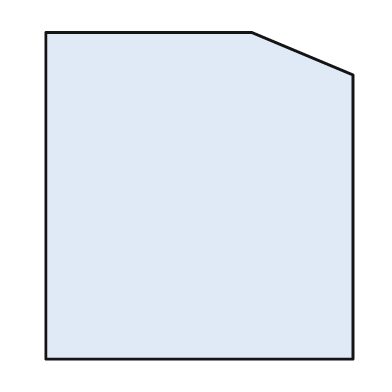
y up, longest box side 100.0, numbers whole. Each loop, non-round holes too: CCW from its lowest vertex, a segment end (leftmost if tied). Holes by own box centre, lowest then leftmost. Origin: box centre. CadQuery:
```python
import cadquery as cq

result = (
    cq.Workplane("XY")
    .moveTo(-47.0, -50.0)
    .lineTo(47.0, -50.0)
    .lineTo(47.0, 37.0)
    .lineTo(16.0, 50.0)
    .lineTo(-47.0, 50.0)
    .close()
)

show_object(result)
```